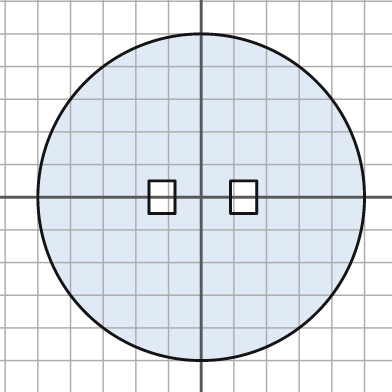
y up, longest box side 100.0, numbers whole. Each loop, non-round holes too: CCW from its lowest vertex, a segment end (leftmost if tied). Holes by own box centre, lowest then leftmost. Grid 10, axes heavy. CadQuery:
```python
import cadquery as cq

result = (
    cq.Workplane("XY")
    .moveTo(0.0, 0.0)
    .circle(50.0)
    .moveTo(-16.0, -5.0)
    .lineTo(-8.0, -5.0)
    .lineTo(-8.0, 5.0)
    .lineTo(-16.0, 5.0)
    .close()
    .moveTo(9.0, -5.0)
    .lineTo(17.0, -5.0)
    .lineTo(17.0, 5.0)
    .lineTo(9.0, 5.0)
    .close()
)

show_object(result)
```